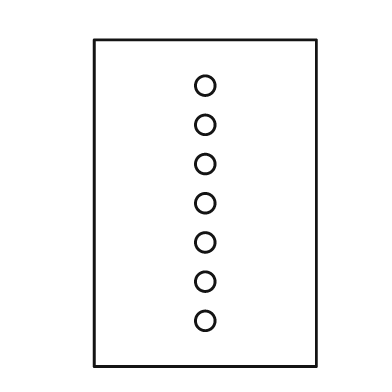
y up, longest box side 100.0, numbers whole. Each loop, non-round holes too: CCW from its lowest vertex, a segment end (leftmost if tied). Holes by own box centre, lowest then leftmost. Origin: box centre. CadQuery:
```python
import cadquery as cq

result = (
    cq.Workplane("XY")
    .moveTo(-34.0, -50.0)
    .lineTo(34.0, -50.0)
    .lineTo(34.0, 50.0)
    .lineTo(-34.0, 50.0)
    .close()
    .moveTo(0.0, -36.0)
    .circle(3.0)
    .moveTo(0.0, -24.0)
    .circle(3.0)
    .moveTo(0.0, -12.0)
    .circle(3.0)
    .moveTo(0.0, 0.0)
    .circle(3.0)
    .moveTo(0.0, 12.0)
    .circle(3.0)
    .moveTo(0.0, 24.0)
    .circle(3.0)
    .moveTo(0.0, 36.0)
    .circle(3.0)
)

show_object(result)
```